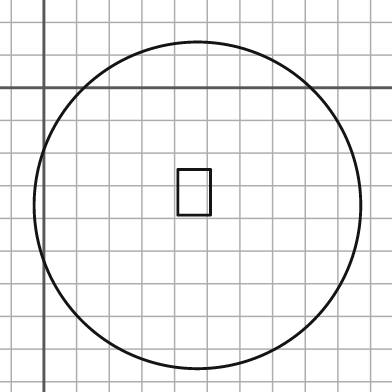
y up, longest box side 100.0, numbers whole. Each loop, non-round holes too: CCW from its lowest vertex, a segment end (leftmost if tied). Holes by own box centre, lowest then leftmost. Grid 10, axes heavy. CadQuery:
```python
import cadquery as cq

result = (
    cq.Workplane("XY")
    .moveTo(47.0, -36.0)
    .circle(50.0)
    .moveTo(41.0, -39.0)
    .lineTo(51.0, -39.0)
    .lineTo(51.0, -25.0)
    .lineTo(41.0, -25.0)
    .close()
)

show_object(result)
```